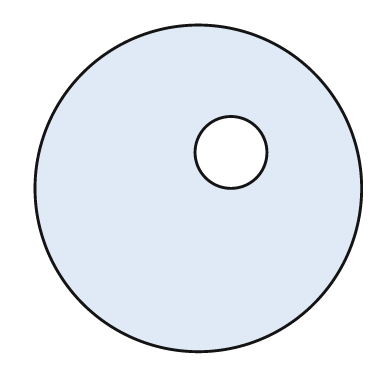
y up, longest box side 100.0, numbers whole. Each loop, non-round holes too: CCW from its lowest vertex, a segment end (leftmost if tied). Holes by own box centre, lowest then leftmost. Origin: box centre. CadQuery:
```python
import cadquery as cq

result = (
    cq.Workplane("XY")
    .moveTo(0.0, 0.0)
    .circle(50.0)
    .moveTo(10.0, 11.0)
    .circle(11.0)
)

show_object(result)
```